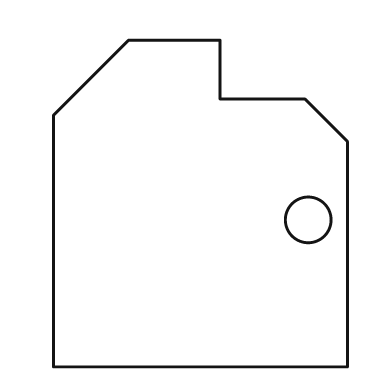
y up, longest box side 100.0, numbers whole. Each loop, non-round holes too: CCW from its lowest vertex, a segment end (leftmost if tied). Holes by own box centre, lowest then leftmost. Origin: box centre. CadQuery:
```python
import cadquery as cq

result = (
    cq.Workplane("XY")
    .moveTo(-45.0, -50.0)
    .lineTo(45.0, -50.0)
    .lineTo(45.0, 19.0)
    .lineTo(32.0, 32.0)
    .lineTo(6.0, 32.0)
    .lineTo(6.0, 50.0)
    .lineTo(-22.0, 50.0)
    .lineTo(-45.0, 27.0)
    .close()
    .moveTo(33.0, -5.0)
    .circle(7.0)
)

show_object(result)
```